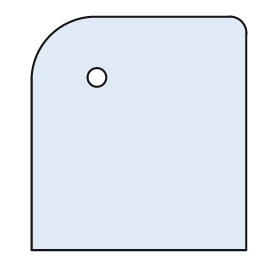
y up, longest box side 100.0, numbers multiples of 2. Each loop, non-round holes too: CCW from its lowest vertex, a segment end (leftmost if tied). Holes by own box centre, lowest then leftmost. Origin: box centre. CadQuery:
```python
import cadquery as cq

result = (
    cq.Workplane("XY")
    .moveTo(-46.0, -50.0)
    .lineTo(46.0, -50.0)
    .lineTo(46.0, 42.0)
    .threePointArc((44.0, 48.0), (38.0, 50.0))
    .lineTo(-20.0, 50.0)
    .threePointArc((-38.0, 42.0), (-46.0, 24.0))
    .close()
    .moveTo(-18.0, 24.0)
    .circle(4.0)
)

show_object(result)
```